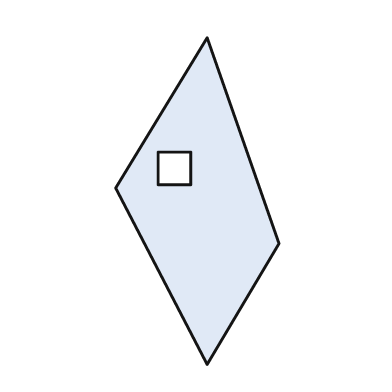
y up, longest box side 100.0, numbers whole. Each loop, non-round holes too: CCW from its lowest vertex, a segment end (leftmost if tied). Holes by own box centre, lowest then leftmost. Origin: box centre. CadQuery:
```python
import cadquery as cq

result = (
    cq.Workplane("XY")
    .moveTo(3.0, -50.0)
    .lineTo(25.0, -13.0)
    .lineTo(3.0, 50.0)
    .lineTo(-25.0, 4.0)
    .close()
    .moveTo(-12.0, 5.0)
    .lineTo(-2.0, 5.0)
    .lineTo(-2.0, 15.0)
    .lineTo(-12.0, 15.0)
    .close()
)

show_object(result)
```